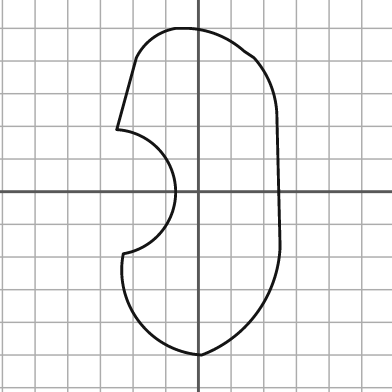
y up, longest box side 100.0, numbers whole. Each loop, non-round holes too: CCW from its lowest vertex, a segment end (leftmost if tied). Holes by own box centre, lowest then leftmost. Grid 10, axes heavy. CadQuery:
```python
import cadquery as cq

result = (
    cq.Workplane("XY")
    .moveTo(1.0, -50.0)
    .threePointArc((18.0, -37.0), (25.0, -17.0))
    .lineTo(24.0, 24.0)
    .threePointArc((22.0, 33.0), (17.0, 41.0))
    .lineTo(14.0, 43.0)
    .threePointArc((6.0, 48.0), (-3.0, 50.0))
    .lineTo(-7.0, 50.0)
    .threePointArc((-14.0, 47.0), (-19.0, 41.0))
    .lineTo(-25.0, 19.0)
    .threePointArc((-7.0, 1.0), (-23.0, -19.0))
    .threePointArc((-18.0, -40.0), (1.0, -50.0))
    .close()
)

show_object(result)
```